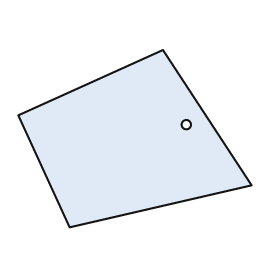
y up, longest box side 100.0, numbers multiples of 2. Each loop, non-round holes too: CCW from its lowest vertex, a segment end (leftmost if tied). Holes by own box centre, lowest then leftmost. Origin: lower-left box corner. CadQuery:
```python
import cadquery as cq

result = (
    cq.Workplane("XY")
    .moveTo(22.0, 0.0)
    .lineTo(100.0, 18.0)
    .lineTo(62.0, 76.0)
    .lineTo(0.0, 48.0)
    .close()
    .moveTo(72.0, 44.0)
    .circle(2.0)
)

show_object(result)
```